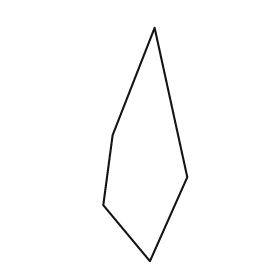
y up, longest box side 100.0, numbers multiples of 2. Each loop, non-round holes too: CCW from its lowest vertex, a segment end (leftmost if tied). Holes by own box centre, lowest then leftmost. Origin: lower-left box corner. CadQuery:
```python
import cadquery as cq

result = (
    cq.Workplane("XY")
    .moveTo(20.0, 0.0)
    .lineTo(36.0, 36.0)
    .lineTo(22.0, 100.0)
    .lineTo(4.0, 54.0)
    .lineTo(0.0, 24.0)
    .close()
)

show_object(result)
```